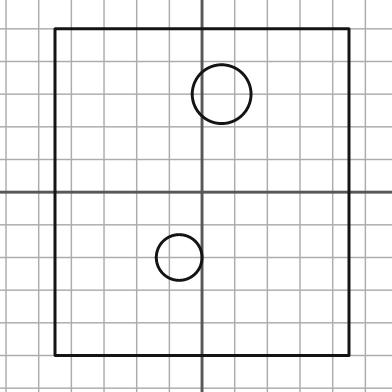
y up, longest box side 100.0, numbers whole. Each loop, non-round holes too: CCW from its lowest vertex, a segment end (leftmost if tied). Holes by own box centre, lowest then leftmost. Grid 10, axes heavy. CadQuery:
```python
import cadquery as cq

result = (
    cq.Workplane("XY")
    .moveTo(-45.0, -50.0)
    .lineTo(45.0, -50.0)
    .lineTo(45.0, 50.0)
    .lineTo(-45.0, 50.0)
    .close()
    .moveTo(-7.0, -20.0)
    .circle(7.0)
    .moveTo(6.0, 30.0)
    .circle(9.0)
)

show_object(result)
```